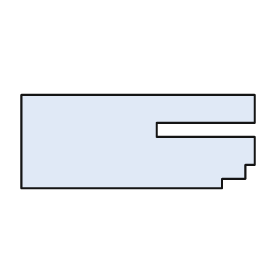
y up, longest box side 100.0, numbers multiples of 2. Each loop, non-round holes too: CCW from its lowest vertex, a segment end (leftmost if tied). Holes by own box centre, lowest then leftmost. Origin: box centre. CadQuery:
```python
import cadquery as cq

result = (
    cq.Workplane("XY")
    .moveTo(-50.0, -20.0)
    .lineTo(36.0, -20.0)
    .lineTo(36.0, -16.0)
    .lineTo(46.0, -16.0)
    .lineTo(46.0, -10.0)
    .lineTo(50.0, -10.0)
    .lineTo(50.0, 2.0)
    .lineTo(8.0, 2.0)
    .lineTo(8.0, 8.0)
    .lineTo(50.0, 8.0)
    .lineTo(50.0, 20.0)
    .lineTo(-50.0, 20.0)
    .close()
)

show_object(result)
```